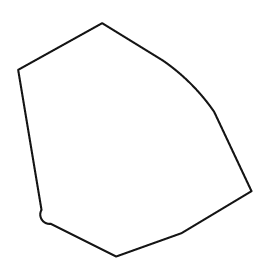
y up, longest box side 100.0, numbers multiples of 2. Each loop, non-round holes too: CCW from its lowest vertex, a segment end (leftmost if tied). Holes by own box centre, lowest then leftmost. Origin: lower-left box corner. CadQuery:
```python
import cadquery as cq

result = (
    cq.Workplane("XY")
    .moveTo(42.0, 0.0)
    .lineTo(70.0, 10.0)
    .lineTo(100.0, 28.0)
    .lineTo(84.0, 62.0)
    .threePointArc((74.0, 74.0), (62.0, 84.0))
    .lineTo(36.0, 100.0)
    .lineTo(0.0, 80.0)
    .lineTo(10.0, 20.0)
    .threePointArc((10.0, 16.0), (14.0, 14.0))
    .close()
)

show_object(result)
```